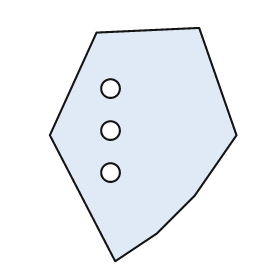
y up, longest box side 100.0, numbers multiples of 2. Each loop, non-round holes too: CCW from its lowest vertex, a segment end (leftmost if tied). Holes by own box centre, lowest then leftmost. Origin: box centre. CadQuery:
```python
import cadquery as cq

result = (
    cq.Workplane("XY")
    .moveTo(-12.0, -50.0)
    .lineTo(6.0, -38.0)
    .lineTo(22.0, -22.0)
    .lineTo(40.0, 4.0)
    .lineTo(24.0, 50.0)
    .lineTo(-20.0, 48.0)
    .lineTo(-40.0, 4.0)
    .close()
    .moveTo(-14.0, -12.0)
    .circle(4.0)
    .moveTo(-14.0, 6.0)
    .circle(4.0)
    .moveTo(-14.0, 24.0)
    .circle(4.0)
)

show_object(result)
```